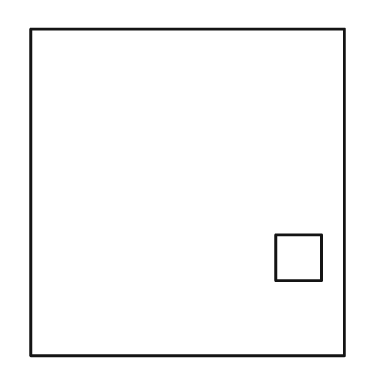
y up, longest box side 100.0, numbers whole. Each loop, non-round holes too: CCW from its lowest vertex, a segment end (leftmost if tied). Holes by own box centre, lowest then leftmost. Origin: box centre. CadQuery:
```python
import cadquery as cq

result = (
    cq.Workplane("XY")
    .moveTo(-48.0, -50.0)
    .lineTo(48.0, -50.0)
    .lineTo(48.0, 50.0)
    .lineTo(-48.0, 50.0)
    .close()
    .moveTo(27.0, -27.0)
    .lineTo(41.0, -27.0)
    .lineTo(41.0, -13.0)
    .lineTo(27.0, -13.0)
    .close()
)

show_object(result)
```